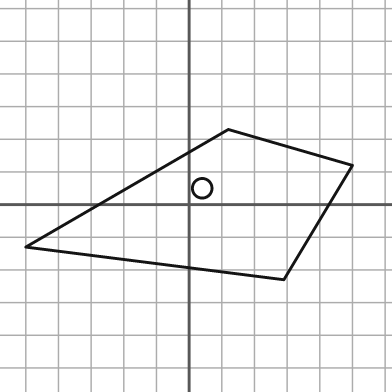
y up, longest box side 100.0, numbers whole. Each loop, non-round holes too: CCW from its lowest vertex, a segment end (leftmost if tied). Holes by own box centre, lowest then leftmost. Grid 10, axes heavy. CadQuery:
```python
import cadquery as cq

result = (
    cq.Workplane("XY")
    .moveTo(29.0, -23.0)
    .lineTo(50.0, 12.0)
    .lineTo(12.0, 23.0)
    .lineTo(-50.0, -13.0)
    .close()
    .moveTo(4.0, 5.0)
    .circle(3.0)
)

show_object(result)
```